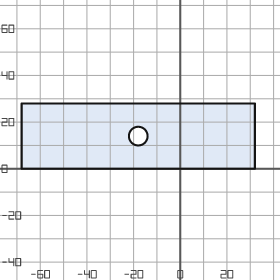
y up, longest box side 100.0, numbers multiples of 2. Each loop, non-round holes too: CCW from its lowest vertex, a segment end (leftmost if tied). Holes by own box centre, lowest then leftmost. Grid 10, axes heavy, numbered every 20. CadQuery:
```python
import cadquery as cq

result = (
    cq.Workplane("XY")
    .moveTo(-68.0, 0.0)
    .lineTo(32.0, 0.0)
    .lineTo(32.0, 28.0)
    .lineTo(-68.0, 28.0)
    .close()
    .moveTo(-18.0, 14.0)
    .circle(4.0)
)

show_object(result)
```